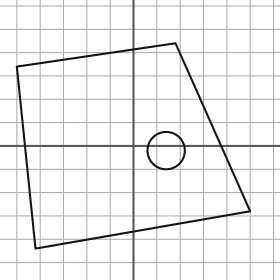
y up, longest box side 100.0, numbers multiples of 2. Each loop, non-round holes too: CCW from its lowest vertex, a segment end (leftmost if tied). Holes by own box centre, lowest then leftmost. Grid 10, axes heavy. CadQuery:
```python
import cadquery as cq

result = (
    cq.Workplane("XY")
    .moveTo(-42.0, -44.0)
    .lineTo(50.0, -28.0)
    .lineTo(18.0, 44.0)
    .lineTo(-50.0, 34.0)
    .close()
    .moveTo(14.0, -2.0)
    .circle(8.0)
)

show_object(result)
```